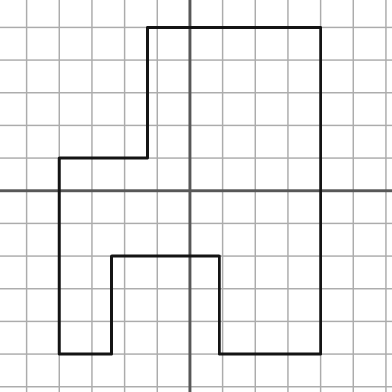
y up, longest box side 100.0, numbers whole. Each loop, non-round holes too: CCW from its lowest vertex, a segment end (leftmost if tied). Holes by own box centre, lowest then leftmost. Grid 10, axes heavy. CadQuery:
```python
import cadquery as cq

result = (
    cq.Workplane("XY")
    .moveTo(-40.0, -50.0)
    .lineTo(-24.0, -50.0)
    .lineTo(-24.0, -20.0)
    .lineTo(9.0, -20.0)
    .lineTo(9.0, -50.0)
    .lineTo(40.0, -50.0)
    .lineTo(40.0, 50.0)
    .lineTo(-13.0, 50.0)
    .lineTo(-13.0, 10.0)
    .lineTo(-40.0, 10.0)
    .close()
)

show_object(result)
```